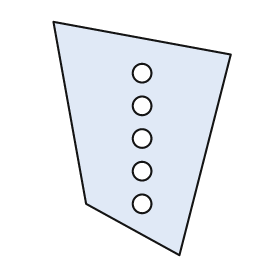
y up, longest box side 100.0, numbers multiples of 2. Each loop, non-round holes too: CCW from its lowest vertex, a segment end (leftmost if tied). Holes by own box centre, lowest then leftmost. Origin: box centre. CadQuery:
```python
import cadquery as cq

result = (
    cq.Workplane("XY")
    .moveTo(16.0, -50.0)
    .lineTo(38.0, 36.0)
    .lineTo(-38.0, 50.0)
    .lineTo(-24.0, -28.0)
    .close()
    .moveTo(0.0, -28.0)
    .circle(4.0)
    .moveTo(0.0, -14.0)
    .circle(4.0)
    .moveTo(0.0, 0.0)
    .circle(4.0)
    .moveTo(0.0, 14.0)
    .circle(4.0)
    .moveTo(0.0, 28.0)
    .circle(4.0)
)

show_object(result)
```